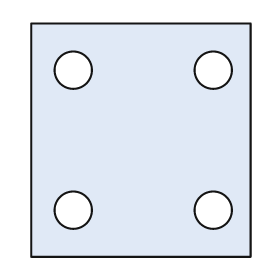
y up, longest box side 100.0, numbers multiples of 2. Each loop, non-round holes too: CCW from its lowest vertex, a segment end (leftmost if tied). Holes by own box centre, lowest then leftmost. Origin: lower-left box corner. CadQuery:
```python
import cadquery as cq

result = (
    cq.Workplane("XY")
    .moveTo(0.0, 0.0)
    .lineTo(94.0, 0.0)
    .lineTo(94.0, 100.0)
    .lineTo(0.0, 100.0)
    .close()
    .moveTo(18.0, 20.0)
    .circle(8.0)
    .moveTo(78.0, 20.0)
    .circle(8.0)
    .moveTo(18.0, 80.0)
    .circle(8.0)
    .moveTo(78.0, 80.0)
    .circle(8.0)
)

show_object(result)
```